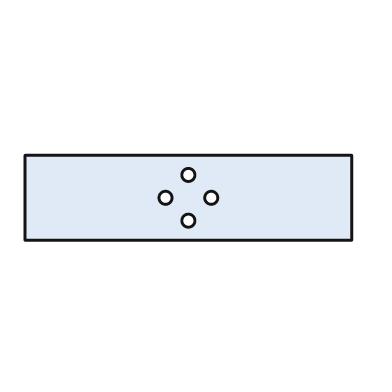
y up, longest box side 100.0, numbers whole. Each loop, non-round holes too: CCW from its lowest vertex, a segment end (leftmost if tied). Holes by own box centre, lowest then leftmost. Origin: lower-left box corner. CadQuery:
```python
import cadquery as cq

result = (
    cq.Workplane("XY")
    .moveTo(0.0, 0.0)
    .lineTo(100.0, 0.0)
    .lineTo(100.0, 26.0)
    .lineTo(0.0, 26.0)
    .close()
    .moveTo(50.0, 6.0)
    .circle(2.0)
    .moveTo(43.0, 13.0)
    .circle(2.0)
    .moveTo(57.0, 13.0)
    .circle(2.0)
    .moveTo(50.0, 20.0)
    .circle(2.0)
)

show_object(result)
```